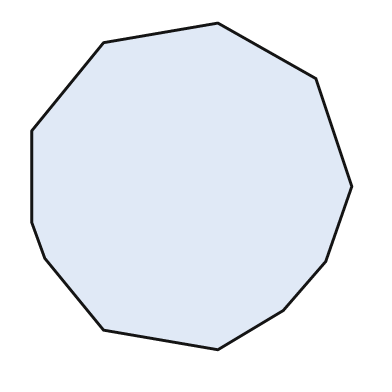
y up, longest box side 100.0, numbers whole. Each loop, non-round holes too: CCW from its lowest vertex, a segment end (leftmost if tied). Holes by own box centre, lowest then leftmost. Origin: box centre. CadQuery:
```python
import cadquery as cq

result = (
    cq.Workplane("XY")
    .moveTo(8.0, -50.0)
    .lineTo(28.0, -38.0)
    .lineTo(41.0, -23.0)
    .lineTo(49.0, 0.0)
    .lineTo(38.0, 33.0)
    .lineTo(8.0, 50.0)
    .lineTo(-27.0, 44.0)
    .lineTo(-49.0, 17.0)
    .lineTo(-49.0, -11.0)
    .lineTo(-45.0, -22.0)
    .lineTo(-27.0, -44.0)
    .close()
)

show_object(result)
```